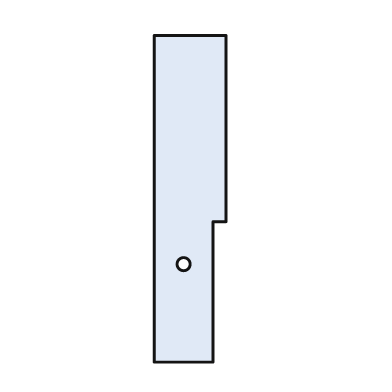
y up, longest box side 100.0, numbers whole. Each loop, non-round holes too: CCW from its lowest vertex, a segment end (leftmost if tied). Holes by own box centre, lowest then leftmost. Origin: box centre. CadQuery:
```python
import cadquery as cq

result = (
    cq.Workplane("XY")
    .moveTo(-11.0, -50.0)
    .lineTo(7.0, -50.0)
    .lineTo(7.0, -7.0)
    .lineTo(11.0, -7.0)
    .lineTo(11.0, 50.0)
    .lineTo(-11.0, 50.0)
    .close()
    .moveTo(-2.0, -20.0)
    .circle(2.0)
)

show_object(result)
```